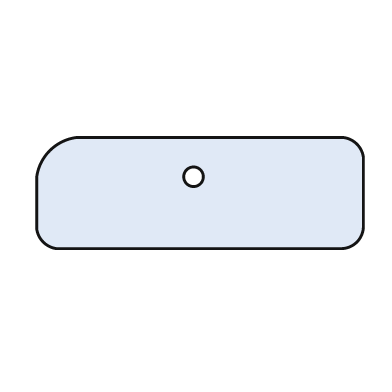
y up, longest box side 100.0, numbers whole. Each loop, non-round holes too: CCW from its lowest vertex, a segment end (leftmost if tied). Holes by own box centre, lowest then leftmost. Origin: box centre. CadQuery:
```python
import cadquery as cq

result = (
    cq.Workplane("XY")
    .moveTo(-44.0, -17.0)
    .lineTo(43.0, -17.0)
    .threePointArc((48.0, -15.0), (50.0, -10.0))
    .lineTo(50.0, 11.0)
    .threePointArc((48.0, 15.0), (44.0, 17.0))
    .lineTo(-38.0, 17.0)
    .threePointArc((-46.0, 13.0), (-50.0, 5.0))
    .lineTo(-50.0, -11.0)
    .threePointArc((-48.0, -15.0), (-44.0, -17.0))
    .close()
    .moveTo(-2.0, 5.0)
    .circle(3.0)
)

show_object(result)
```